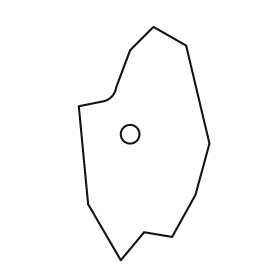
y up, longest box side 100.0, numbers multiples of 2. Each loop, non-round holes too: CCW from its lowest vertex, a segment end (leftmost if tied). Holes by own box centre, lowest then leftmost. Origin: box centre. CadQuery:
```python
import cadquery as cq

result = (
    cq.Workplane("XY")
    .moveTo(-10.0, -50.0)
    .lineTo(0.0, -38.0)
    .lineTo(12.0, -40.0)
    .lineTo(22.0, -22.0)
    .lineTo(28.0, 0.0)
    .lineTo(18.0, 42.0)
    .lineTo(4.0, 50.0)
    .lineTo(-6.0, 40.0)
    .lineTo(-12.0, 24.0)
    .threePointArc((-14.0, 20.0), (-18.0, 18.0))
    .lineTo(-28.0, 16.0)
    .lineTo(-24.0, -26.0)
    .close()
    .moveTo(-6.0, 4.0)
    .circle(4.0)
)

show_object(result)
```